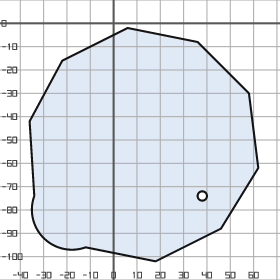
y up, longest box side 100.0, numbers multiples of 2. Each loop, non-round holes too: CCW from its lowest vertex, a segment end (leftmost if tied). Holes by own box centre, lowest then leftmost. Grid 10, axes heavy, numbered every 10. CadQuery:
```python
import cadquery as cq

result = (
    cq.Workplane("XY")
    .moveTo(18.0, -102.0)
    .lineTo(46.0, -88.0)
    .lineTo(62.0, -62.0)
    .lineTo(58.0, -30.0)
    .lineTo(36.0, -8.0)
    .lineTo(6.0, -2.0)
    .lineTo(-22.0, -16.0)
    .lineTo(-36.0, -42.0)
    .lineTo(-34.0, -74.0)
    .threePointArc((-30.0, -92.0), (-12.0, -96.0))
    .close()
    .moveTo(38.0, -74.0)
    .circle(2.0)
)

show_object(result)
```